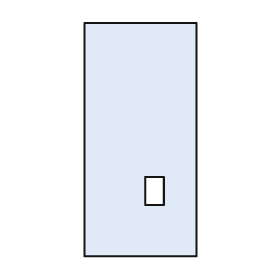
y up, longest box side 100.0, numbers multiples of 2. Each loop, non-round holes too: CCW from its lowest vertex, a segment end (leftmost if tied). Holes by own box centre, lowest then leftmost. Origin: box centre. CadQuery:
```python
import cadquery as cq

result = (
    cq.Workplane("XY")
    .moveTo(-24.0, -50.0)
    .lineTo(24.0, -50.0)
    .lineTo(24.0, 50.0)
    .lineTo(-24.0, 50.0)
    .close()
    .moveTo(2.0, -28.0)
    .lineTo(10.0, -28.0)
    .lineTo(10.0, -16.0)
    .lineTo(2.0, -16.0)
    .close()
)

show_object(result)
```